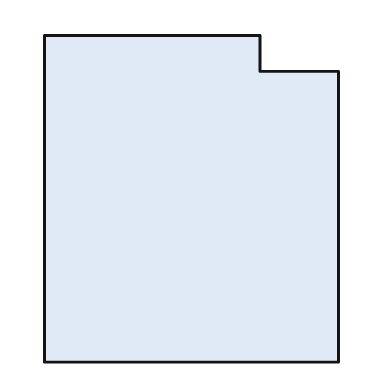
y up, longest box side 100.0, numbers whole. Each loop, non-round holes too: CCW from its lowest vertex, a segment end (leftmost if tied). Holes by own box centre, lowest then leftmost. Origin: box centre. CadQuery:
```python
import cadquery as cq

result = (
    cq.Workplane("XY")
    .moveTo(-45.0, -50.0)
    .lineTo(45.0, -50.0)
    .lineTo(45.0, 39.0)
    .lineTo(21.0, 39.0)
    .lineTo(21.0, 50.0)
    .lineTo(-45.0, 50.0)
    .close()
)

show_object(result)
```